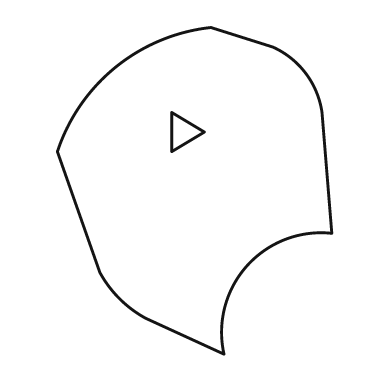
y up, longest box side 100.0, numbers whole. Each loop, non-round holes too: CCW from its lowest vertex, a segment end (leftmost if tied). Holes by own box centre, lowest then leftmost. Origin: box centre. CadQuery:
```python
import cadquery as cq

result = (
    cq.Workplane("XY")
    .moveTo(9.0, -50.0)
    .threePointArc((16.0, -23.0), (42.0, -13.0))
    .lineTo(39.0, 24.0)
    .threePointArc((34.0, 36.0), (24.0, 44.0))
    .lineTo(5.0, 50.0)
    .threePointArc((-24.0, 38.0), (-42.0, 12.0))
    .lineTo(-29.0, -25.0)
    .threePointArc((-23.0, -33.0), (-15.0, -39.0))
    .close()
    .moveTo(-7.0, 12.0)
    .lineTo(3.0, 18.0)
    .lineTo(-7.0, 24.0)
    .close()
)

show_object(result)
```